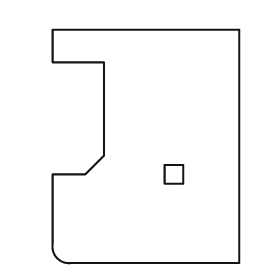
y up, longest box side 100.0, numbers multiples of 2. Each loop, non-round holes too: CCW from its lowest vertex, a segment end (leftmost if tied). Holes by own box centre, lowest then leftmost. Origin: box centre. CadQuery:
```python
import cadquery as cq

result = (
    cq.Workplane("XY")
    .moveTo(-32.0, -50.0)
    .lineTo(40.0, -50.0)
    .lineTo(40.0, 50.0)
    .lineTo(-40.0, 50.0)
    .lineTo(-40.0, 36.0)
    .lineTo(-18.0, 36.0)
    .lineTo(-18.0, -4.0)
    .lineTo(-26.0, -12.0)
    .lineTo(-40.0, -12.0)
    .lineTo(-40.0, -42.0)
    .threePointArc((-38.0, -48.0), (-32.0, -50.0))
    .close()
    .moveTo(8.0, -16.0)
    .lineTo(16.0, -16.0)
    .lineTo(16.0, -8.0)
    .lineTo(8.0, -8.0)
    .close()
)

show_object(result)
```